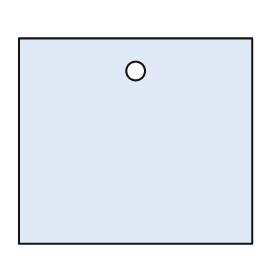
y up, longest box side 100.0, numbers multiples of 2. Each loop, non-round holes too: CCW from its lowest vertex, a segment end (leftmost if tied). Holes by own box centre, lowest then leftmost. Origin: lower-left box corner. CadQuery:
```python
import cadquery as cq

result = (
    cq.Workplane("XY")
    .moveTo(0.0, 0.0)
    .lineTo(100.0, 0.0)
    .lineTo(100.0, 88.0)
    .lineTo(0.0, 88.0)
    .close()
    .moveTo(50.0, 74.0)
    .circle(4.0)
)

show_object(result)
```